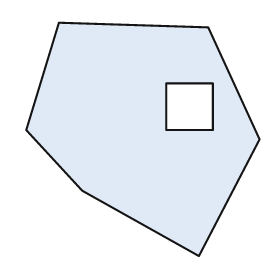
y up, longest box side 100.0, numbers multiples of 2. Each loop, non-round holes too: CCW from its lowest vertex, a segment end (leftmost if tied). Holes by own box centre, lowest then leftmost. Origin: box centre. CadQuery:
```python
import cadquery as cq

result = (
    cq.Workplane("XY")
    .moveTo(24.0, -50.0)
    .lineTo(50.0, 0.0)
    .lineTo(28.0, 48.0)
    .lineTo(-36.0, 50.0)
    .lineTo(-50.0, 4.0)
    .lineTo(-26.0, -22.0)
    .close()
    .moveTo(10.0, 4.0)
    .lineTo(30.0, 4.0)
    .lineTo(30.0, 24.0)
    .lineTo(10.0, 24.0)
    .close()
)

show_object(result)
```